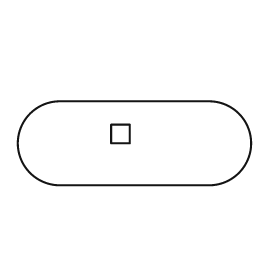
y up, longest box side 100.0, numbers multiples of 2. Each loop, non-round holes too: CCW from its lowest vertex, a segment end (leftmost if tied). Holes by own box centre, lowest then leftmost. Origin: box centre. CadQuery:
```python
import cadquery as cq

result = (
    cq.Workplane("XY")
    .moveTo(-32.0, -18.0)
    .lineTo(32.0, -18.0)
    .threePointArc((50.0, 0.0), (32.0, 18.0))
    .lineTo(-32.0, 18.0)
    .threePointArc((-50.0, 0.0), (-32.0, -18.0))
    .close()
    .moveTo(-10.0, 0.0)
    .lineTo(-2.0, 0.0)
    .lineTo(-2.0, 8.0)
    .lineTo(-10.0, 8.0)
    .close()
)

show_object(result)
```